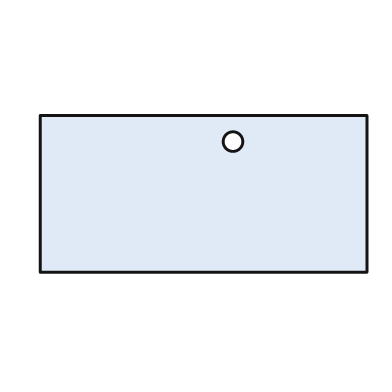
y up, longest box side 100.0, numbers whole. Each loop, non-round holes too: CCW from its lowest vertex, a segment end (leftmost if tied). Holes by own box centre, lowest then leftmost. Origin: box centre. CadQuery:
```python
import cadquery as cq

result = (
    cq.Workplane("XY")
    .moveTo(-50.0, -24.0)
    .lineTo(50.0, -24.0)
    .lineTo(50.0, 24.0)
    .lineTo(-50.0, 24.0)
    .close()
    .moveTo(9.0, 16.0)
    .circle(3.0)
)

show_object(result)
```